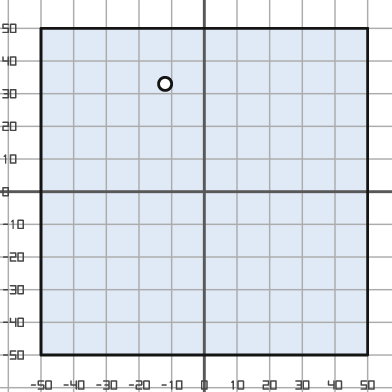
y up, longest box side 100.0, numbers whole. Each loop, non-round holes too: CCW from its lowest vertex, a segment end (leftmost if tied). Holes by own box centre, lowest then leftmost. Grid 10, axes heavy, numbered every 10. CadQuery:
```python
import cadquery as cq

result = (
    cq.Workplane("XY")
    .moveTo(-50.0, -50.0)
    .lineTo(50.0, -50.0)
    .lineTo(50.0, 50.0)
    .lineTo(-50.0, 50.0)
    .close()
    .moveTo(-12.0, 33.0)
    .circle(2.0)
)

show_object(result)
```